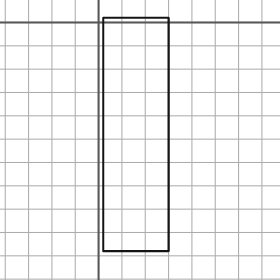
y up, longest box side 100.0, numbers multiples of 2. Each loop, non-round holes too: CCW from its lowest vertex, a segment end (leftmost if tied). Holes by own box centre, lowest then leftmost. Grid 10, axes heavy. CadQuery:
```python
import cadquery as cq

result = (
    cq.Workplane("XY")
    .moveTo(2.0, -98.0)
    .lineTo(30.0, -98.0)
    .lineTo(30.0, 2.0)
    .lineTo(2.0, 2.0)
    .close()
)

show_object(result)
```